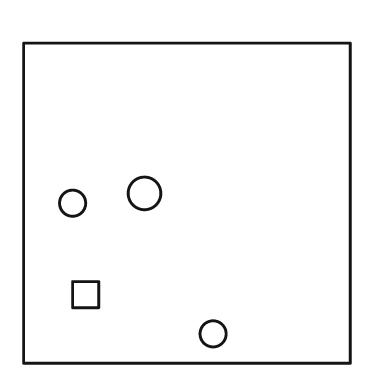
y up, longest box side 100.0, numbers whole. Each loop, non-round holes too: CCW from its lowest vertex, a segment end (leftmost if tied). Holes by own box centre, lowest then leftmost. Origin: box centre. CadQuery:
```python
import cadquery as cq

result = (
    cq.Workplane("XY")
    .moveTo(-50.0, -49.0)
    .lineTo(50.0, -49.0)
    .lineTo(50.0, 49.0)
    .lineTo(-50.0, 49.0)
    .close()
    .moveTo(8.0, -40.0)
    .circle(4.0)
    .moveTo(-35.0, -32.0)
    .lineTo(-27.0, -32.0)
    .lineTo(-27.0, -24.0)
    .lineTo(-35.0, -24.0)
    .close()
    .moveTo(-35.0, 0.0)
    .circle(4.0)
    .moveTo(-13.0, 3.0)
    .circle(5.0)
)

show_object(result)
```